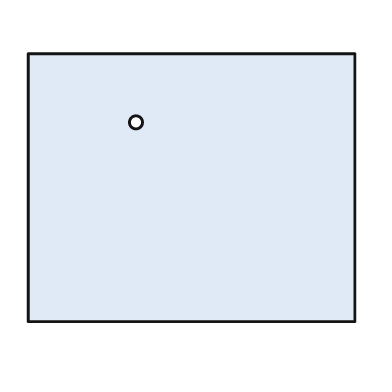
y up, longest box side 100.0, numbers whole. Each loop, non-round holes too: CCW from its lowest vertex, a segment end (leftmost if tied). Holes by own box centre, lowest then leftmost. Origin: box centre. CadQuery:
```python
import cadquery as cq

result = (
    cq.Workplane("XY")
    .moveTo(-50.0, -41.0)
    .lineTo(50.0, -41.0)
    .lineTo(50.0, 41.0)
    .lineTo(-50.0, 41.0)
    .close()
    .moveTo(-17.0, 20.0)
    .circle(2.0)
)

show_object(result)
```